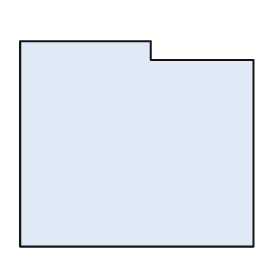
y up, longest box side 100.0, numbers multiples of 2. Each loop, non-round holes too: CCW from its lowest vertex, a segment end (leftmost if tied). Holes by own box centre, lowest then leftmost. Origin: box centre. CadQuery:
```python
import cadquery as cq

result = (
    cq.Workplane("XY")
    .moveTo(-50.0, -44.0)
    .lineTo(50.0, -44.0)
    .lineTo(50.0, 36.0)
    .lineTo(6.0, 36.0)
    .lineTo(6.0, 44.0)
    .lineTo(-50.0, 44.0)
    .close()
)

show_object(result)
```